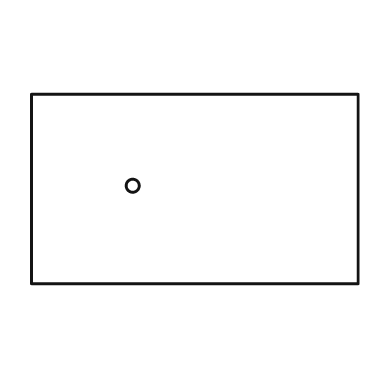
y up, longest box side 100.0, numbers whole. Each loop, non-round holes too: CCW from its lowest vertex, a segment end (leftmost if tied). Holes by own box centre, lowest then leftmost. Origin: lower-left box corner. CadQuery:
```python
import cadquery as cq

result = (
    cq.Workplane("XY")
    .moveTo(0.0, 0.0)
    .lineTo(100.0, 0.0)
    .lineTo(100.0, 58.0)
    .lineTo(0.0, 58.0)
    .close()
    .moveTo(31.0, 30.0)
    .circle(2.0)
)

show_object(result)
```